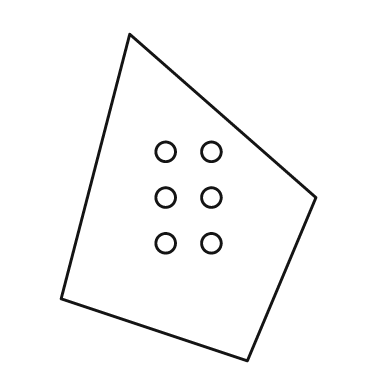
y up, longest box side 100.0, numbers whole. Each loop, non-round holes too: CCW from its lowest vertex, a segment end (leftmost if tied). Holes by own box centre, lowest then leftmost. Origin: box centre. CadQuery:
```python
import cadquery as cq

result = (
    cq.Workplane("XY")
    .moveTo(18.0, -50.0)
    .lineTo(39.0, 0.0)
    .lineTo(-18.0, 50.0)
    .lineTo(-39.0, -31.0)
    .close()
    .moveTo(-7.0, -14.0)
    .circle(3.0)
    .moveTo(7.0, -14.0)
    .circle(3.0)
    .moveTo(-7.0, 0.0)
    .circle(3.0)
    .moveTo(7.0, 0.0)
    .circle(3.0)
    .moveTo(-7.0, 14.0)
    .circle(3.0)
    .moveTo(7.0, 14.0)
    .circle(3.0)
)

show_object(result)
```